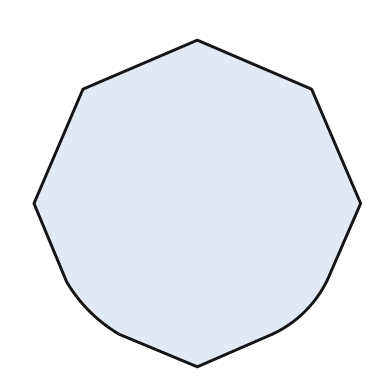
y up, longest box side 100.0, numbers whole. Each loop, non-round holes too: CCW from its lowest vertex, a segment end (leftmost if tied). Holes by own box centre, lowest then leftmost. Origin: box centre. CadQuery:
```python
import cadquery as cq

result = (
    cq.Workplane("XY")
    .moveTo(0.0, -50.0)
    .lineTo(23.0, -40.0)
    .threePointArc((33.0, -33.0), (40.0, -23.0))
    .lineTo(50.0, 0.0)
    .lineTo(35.0, 35.0)
    .lineTo(0.0, 50.0)
    .lineTo(-35.0, 35.0)
    .lineTo(-50.0, 0.0)
    .lineTo(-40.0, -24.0)
    .threePointArc((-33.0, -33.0), (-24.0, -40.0))
    .close()
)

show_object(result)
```